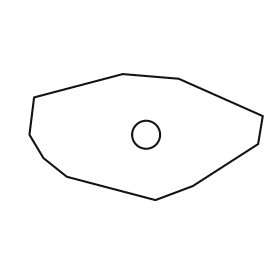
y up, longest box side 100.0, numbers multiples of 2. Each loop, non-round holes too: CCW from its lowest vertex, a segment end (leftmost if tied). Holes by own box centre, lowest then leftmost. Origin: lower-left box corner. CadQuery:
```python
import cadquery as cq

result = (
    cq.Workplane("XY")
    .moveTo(54.0, 0.0)
    .lineTo(70.0, 6.0)
    .lineTo(98.0, 24.0)
    .lineTo(100.0, 36.0)
    .lineTo(64.0, 52.0)
    .lineTo(40.0, 54.0)
    .lineTo(2.0, 44.0)
    .lineTo(0.0, 28.0)
    .lineTo(6.0, 18.0)
    .lineTo(16.0, 10.0)
    .close()
    .moveTo(50.0, 28.0)
    .circle(6.0)
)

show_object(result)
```